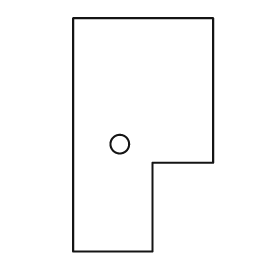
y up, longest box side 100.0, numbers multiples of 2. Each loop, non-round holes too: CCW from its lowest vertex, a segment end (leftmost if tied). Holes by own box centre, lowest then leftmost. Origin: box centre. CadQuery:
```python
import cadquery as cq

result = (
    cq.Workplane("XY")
    .moveTo(-30.0, -50.0)
    .lineTo(4.0, -50.0)
    .lineTo(4.0, -12.0)
    .lineTo(30.0, -12.0)
    .lineTo(30.0, 50.0)
    .lineTo(-30.0, 50.0)
    .close()
    .moveTo(-10.0, -4.0)
    .circle(4.0)
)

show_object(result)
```